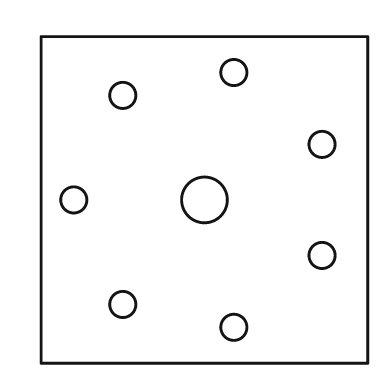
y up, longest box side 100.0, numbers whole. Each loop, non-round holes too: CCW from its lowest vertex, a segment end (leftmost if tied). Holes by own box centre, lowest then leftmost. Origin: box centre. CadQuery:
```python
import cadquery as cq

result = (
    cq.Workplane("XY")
    .moveTo(-50.0, -50.0)
    .lineTo(50.0, -50.0)
    .lineTo(50.0, 50.0)
    .lineTo(-50.0, 50.0)
    .close()
    .moveTo(9.0, -39.0)
    .circle(4.0)
    .moveTo(-25.0, -32.0)
    .circle(4.0)
    .moveTo(36.0, -17.0)
    .circle(4.0)
    .moveTo(-40.0, 0.0)
    .circle(4.0)
    .moveTo(0.0, 0.0)
    .circle(7.0)
    .moveTo(36.0, 17.0)
    .circle(4.0)
    .moveTo(-25.0, 32.0)
    .circle(4.0)
    .moveTo(9.0, 39.0)
    .circle(4.0)
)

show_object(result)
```